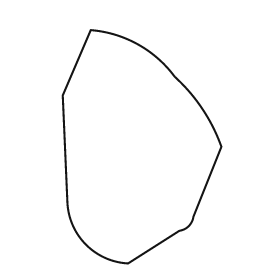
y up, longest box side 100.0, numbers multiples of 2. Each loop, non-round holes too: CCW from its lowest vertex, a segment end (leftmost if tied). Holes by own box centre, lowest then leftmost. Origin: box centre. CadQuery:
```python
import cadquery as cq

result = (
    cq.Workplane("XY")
    .moveTo(-6.0, -50.0)
    .lineTo(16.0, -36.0)
    .threePointArc((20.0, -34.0), (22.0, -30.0))
    .lineTo(34.0, 0.0)
    .threePointArc((26.0, 16.0), (14.0, 30.0))
    .threePointArc((-2.0, 44.0), (-22.0, 50.0))
    .lineTo(-34.0, 22.0)
    .lineTo(-32.0, -24.0)
    .threePointArc((-24.0, -42.0), (-6.0, -50.0))
    .close()
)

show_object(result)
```